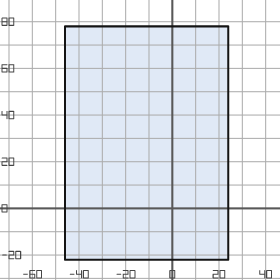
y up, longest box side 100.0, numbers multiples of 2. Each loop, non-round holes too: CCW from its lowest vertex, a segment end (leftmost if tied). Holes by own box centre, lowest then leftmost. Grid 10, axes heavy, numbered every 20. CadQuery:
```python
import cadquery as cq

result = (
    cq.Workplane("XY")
    .moveTo(-46.0, -22.0)
    .lineTo(24.0, -22.0)
    .lineTo(24.0, 78.0)
    .lineTo(-46.0, 78.0)
    .close()
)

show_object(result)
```